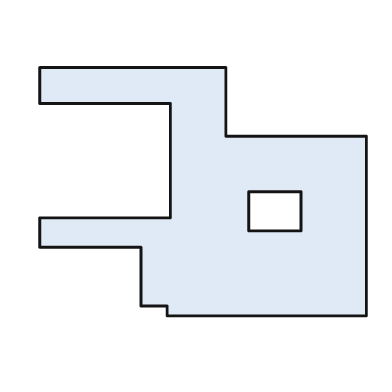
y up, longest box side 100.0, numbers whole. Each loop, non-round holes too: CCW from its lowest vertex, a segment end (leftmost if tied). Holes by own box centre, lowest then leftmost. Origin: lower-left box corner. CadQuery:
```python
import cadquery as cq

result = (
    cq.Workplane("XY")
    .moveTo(39.0, 0.0)
    .lineTo(100.0, 0.0)
    .lineTo(100.0, 55.0)
    .lineTo(57.0, 55.0)
    .lineTo(57.0, 76.0)
    .lineTo(0.0, 76.0)
    .lineTo(0.0, 65.0)
    .lineTo(40.0, 65.0)
    .lineTo(40.0, 30.0)
    .lineTo(0.0, 30.0)
    .lineTo(0.0, 21.0)
    .lineTo(31.0, 21.0)
    .lineTo(31.0, 3.0)
    .lineTo(39.0, 3.0)
    .close()
    .moveTo(64.0, 26.0)
    .lineTo(80.0, 26.0)
    .lineTo(80.0, 38.0)
    .lineTo(64.0, 38.0)
    .close()
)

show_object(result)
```